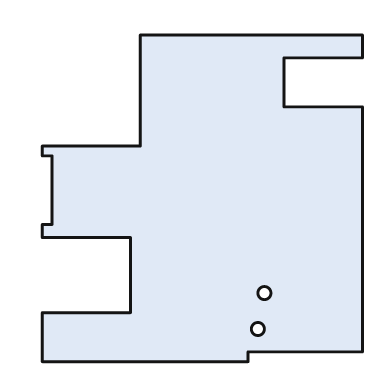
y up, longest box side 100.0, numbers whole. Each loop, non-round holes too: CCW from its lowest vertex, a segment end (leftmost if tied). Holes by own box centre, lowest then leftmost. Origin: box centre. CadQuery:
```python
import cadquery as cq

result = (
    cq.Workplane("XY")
    .moveTo(-49.0, -50.0)
    .lineTo(14.0, -50.0)
    .lineTo(14.0, -47.0)
    .lineTo(49.0, -47.0)
    .lineTo(49.0, 28.0)
    .lineTo(25.0, 28.0)
    .lineTo(25.0, 43.0)
    .lineTo(49.0, 43.0)
    .lineTo(49.0, 50.0)
    .lineTo(-19.0, 50.0)
    .lineTo(-19.0, 16.0)
    .lineTo(-49.0, 16.0)
    .lineTo(-49.0, 13.0)
    .lineTo(-46.0, 13.0)
    .lineTo(-46.0, -8.0)
    .lineTo(-49.0, -8.0)
    .lineTo(-49.0, -12.0)
    .lineTo(-22.0, -12.0)
    .lineTo(-22.0, -35.0)
    .lineTo(-49.0, -35.0)
    .close()
    .moveTo(17.0, -40.0)
    .circle(2.0)
    .moveTo(19.0, -29.0)
    .circle(2.0)
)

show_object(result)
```